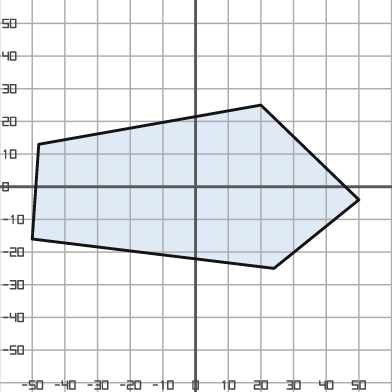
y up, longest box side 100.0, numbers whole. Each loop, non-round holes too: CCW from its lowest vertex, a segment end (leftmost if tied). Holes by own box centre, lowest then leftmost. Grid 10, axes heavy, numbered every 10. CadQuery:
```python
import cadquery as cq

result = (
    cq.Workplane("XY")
    .moveTo(24.0, -25.0)
    .lineTo(50.0, -4.0)
    .lineTo(20.0, 25.0)
    .lineTo(-48.0, 13.0)
    .lineTo(-50.0, -16.0)
    .close()
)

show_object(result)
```